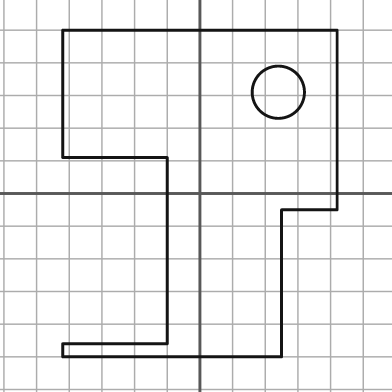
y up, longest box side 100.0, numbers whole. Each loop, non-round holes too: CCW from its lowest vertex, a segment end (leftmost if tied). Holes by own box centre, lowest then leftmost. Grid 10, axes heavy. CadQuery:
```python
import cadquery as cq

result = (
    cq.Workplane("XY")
    .moveTo(-42.0, -50.0)
    .lineTo(25.0, -50.0)
    .lineTo(25.0, -5.0)
    .lineTo(42.0, -5.0)
    .lineTo(42.0, 50.0)
    .lineTo(-42.0, 50.0)
    .lineTo(-42.0, 11.0)
    .lineTo(-10.0, 11.0)
    .lineTo(-10.0, -46.0)
    .lineTo(-42.0, -46.0)
    .close()
    .moveTo(24.0, 31.0)
    .circle(8.0)
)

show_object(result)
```